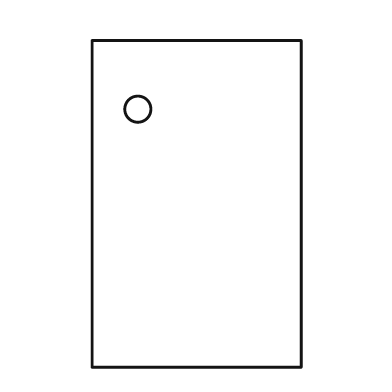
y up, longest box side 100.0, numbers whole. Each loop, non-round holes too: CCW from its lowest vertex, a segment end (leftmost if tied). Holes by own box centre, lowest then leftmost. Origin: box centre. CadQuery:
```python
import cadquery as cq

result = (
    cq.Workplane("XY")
    .moveTo(-32.0, -50.0)
    .lineTo(32.0, -50.0)
    .lineTo(32.0, 50.0)
    .lineTo(-32.0, 50.0)
    .close()
    .moveTo(-18.0, 29.0)
    .circle(4.0)
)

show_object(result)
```